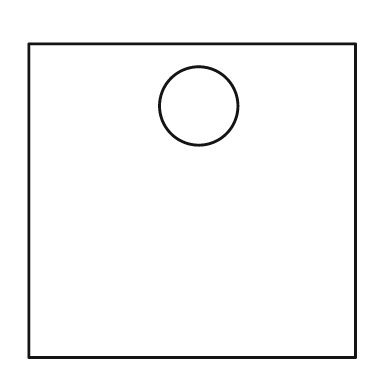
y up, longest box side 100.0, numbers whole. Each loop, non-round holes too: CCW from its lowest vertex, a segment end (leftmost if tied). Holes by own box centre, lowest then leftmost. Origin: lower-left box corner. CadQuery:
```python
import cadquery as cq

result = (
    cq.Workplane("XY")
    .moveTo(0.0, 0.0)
    .lineTo(100.0, 0.0)
    .lineTo(100.0, 96.0)
    .lineTo(0.0, 96.0)
    .close()
    .moveTo(52.0, 77.0)
    .circle(12.0)
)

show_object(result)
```